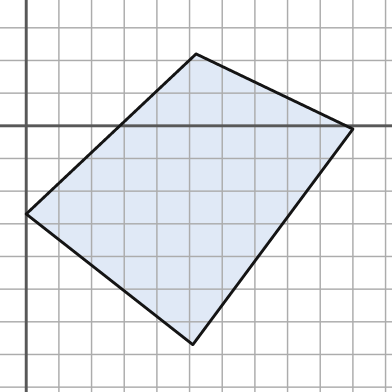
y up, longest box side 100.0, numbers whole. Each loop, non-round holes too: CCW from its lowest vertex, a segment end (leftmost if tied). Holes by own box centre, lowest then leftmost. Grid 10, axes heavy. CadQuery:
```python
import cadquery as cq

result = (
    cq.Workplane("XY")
    .moveTo(51.0, -67.0)
    .lineTo(100.0, -1.0)
    .lineTo(52.0, 22.0)
    .lineTo(0.0, -27.0)
    .close()
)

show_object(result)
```